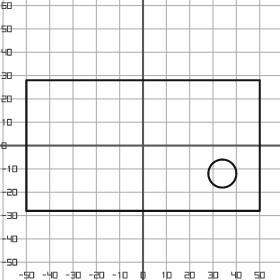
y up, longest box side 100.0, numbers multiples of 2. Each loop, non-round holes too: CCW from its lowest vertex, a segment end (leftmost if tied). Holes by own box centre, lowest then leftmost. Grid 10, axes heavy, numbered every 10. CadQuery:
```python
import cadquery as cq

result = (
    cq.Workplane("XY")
    .moveTo(-50.0, -28.0)
    .lineTo(50.0, -28.0)
    .lineTo(50.0, 28.0)
    .lineTo(-50.0, 28.0)
    .close()
    .moveTo(34.0, -12.0)
    .circle(6.0)
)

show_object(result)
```